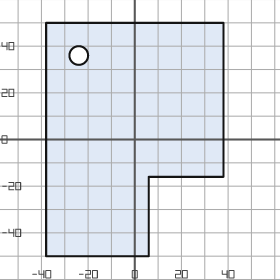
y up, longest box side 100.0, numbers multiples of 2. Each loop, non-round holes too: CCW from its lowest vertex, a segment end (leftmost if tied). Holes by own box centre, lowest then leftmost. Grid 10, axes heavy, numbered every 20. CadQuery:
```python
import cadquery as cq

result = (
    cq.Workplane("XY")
    .moveTo(-38.0, -50.0)
    .lineTo(6.0, -50.0)
    .lineTo(6.0, -16.0)
    .lineTo(38.0, -16.0)
    .lineTo(38.0, 50.0)
    .lineTo(-38.0, 50.0)
    .close()
    .moveTo(-24.0, 36.0)
    .circle(4.0)
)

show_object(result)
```